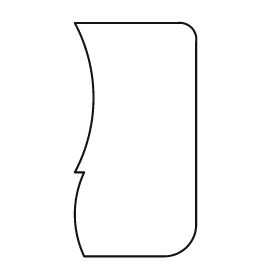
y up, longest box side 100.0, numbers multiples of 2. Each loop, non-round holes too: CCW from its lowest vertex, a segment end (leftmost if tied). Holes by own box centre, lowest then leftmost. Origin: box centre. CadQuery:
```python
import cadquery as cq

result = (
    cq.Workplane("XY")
    .moveTo(-22.0, -50.0)
    .lineTo(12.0, -50.0)
    .threePointArc((22.0, -46.0), (26.0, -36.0))
    .lineTo(26.0, 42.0)
    .threePointArc((24.0, 48.0), (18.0, 50.0))
    .lineTo(-26.0, 50.0)
    .threePointArc((-18.0, 18.0), (-26.0, -14.0))
    .lineTo(-22.0, -14.0)
    .threePointArc((-26.0, -32.0), (-22.0, -50.0))
    .close()
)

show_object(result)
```